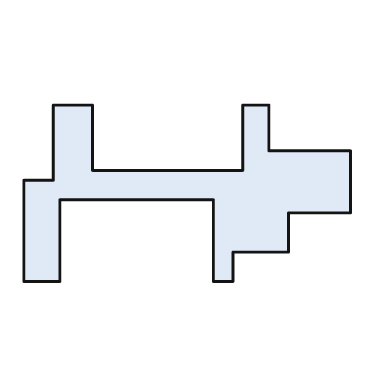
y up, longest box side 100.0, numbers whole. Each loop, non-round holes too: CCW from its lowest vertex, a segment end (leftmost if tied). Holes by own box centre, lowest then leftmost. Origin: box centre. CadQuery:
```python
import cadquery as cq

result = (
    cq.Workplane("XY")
    .moveTo(-50.0, -27.0)
    .lineTo(-39.0, -27.0)
    .lineTo(-39.0, -2.0)
    .lineTo(8.0, -2.0)
    .lineTo(8.0, -27.0)
    .lineTo(14.0, -27.0)
    .lineTo(14.0, -18.0)
    .lineTo(31.0, -18.0)
    .lineTo(31.0, -6.0)
    .lineTo(50.0, -6.0)
    .lineTo(50.0, 13.0)
    .lineTo(25.0, 13.0)
    .lineTo(25.0, 27.0)
    .lineTo(17.0, 27.0)
    .lineTo(17.0, 7.0)
    .lineTo(-29.0, 7.0)
    .lineTo(-29.0, 27.0)
    .lineTo(-41.0, 27.0)
    .lineTo(-41.0, 4.0)
    .lineTo(-50.0, 4.0)
    .close()
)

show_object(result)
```